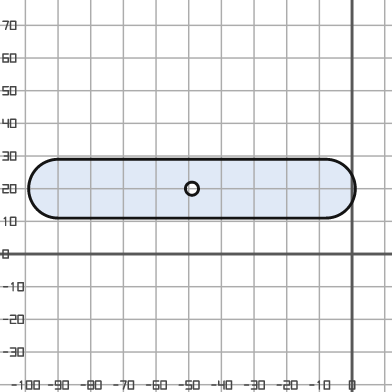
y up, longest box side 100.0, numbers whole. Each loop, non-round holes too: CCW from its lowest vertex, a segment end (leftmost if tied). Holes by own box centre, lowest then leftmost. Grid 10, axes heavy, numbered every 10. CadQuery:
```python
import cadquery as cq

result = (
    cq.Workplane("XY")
    .moveTo(-90.0, 11.0)
    .lineTo(-8.0, 11.0)
    .threePointArc((1.0, 20.0), (-8.0, 29.0))
    .lineTo(-90.0, 29.0)
    .threePointArc((-99.0, 20.0), (-90.0, 11.0))
    .close()
    .moveTo(-49.0, 20.0)
    .circle(2.0)
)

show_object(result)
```